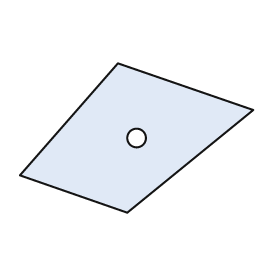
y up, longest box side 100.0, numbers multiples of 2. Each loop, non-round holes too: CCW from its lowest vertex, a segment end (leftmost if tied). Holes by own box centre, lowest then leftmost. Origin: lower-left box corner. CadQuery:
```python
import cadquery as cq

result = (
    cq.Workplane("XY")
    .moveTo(46.0, 0.0)
    .lineTo(100.0, 44.0)
    .lineTo(42.0, 64.0)
    .lineTo(0.0, 16.0)
    .close()
    .moveTo(50.0, 32.0)
    .circle(4.0)
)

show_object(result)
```